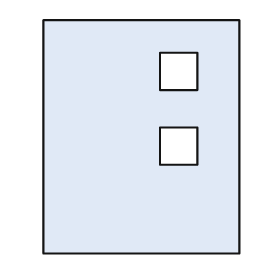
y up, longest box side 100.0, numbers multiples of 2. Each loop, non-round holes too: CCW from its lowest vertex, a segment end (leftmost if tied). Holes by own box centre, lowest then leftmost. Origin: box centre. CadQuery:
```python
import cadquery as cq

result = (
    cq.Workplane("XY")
    .moveTo(-42.0, -50.0)
    .lineTo(42.0, -50.0)
    .lineTo(42.0, 50.0)
    .lineTo(-42.0, 50.0)
    .close()
    .moveTo(8.0, -12.0)
    .lineTo(24.0, -12.0)
    .lineTo(24.0, 4.0)
    .lineTo(8.0, 4.0)
    .close()
    .moveTo(8.0, 20.0)
    .lineTo(24.0, 20.0)
    .lineTo(24.0, 36.0)
    .lineTo(8.0, 36.0)
    .close()
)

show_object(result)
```